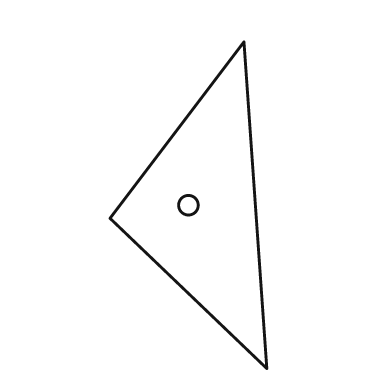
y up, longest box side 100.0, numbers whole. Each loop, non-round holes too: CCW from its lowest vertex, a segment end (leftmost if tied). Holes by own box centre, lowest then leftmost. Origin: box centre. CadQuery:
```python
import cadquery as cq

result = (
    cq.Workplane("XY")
    .moveTo(24.0, -50.0)
    .lineTo(17.0, 50.0)
    .lineTo(-24.0, -4.0)
    .close()
    .moveTo(0.0, 0.0)
    .circle(3.0)
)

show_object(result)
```